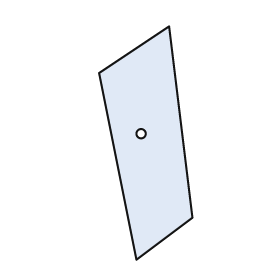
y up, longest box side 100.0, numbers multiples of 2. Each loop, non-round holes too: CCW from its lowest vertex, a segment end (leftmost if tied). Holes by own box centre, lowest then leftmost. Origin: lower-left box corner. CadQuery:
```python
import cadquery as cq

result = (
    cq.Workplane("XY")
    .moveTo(16.0, 0.0)
    .lineTo(40.0, 18.0)
    .lineTo(30.0, 100.0)
    .lineTo(0.0, 80.0)
    .close()
    .moveTo(18.0, 54.0)
    .circle(2.0)
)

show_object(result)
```